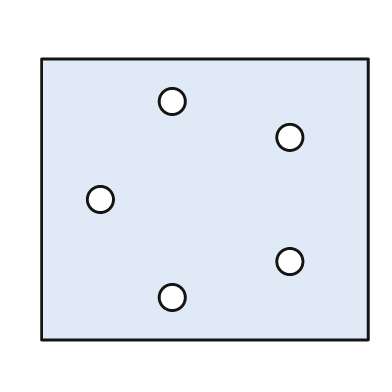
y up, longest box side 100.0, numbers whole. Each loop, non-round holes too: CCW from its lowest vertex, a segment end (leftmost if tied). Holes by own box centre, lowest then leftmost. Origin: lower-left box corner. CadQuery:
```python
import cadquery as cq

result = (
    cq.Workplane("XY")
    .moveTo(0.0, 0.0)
    .lineTo(100.0, 0.0)
    .lineTo(100.0, 86.0)
    .lineTo(0.0, 86.0)
    .close()
    .moveTo(40.0, 13.0)
    .circle(4.0)
    .moveTo(76.0, 24.0)
    .circle(4.0)
    .moveTo(18.0, 43.0)
    .circle(4.0)
    .moveTo(76.0, 62.0)
    .circle(4.0)
    .moveTo(40.0, 73.0)
    .circle(4.0)
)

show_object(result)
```